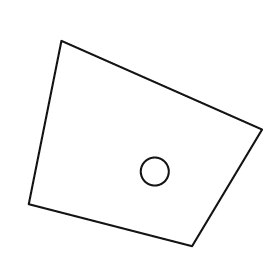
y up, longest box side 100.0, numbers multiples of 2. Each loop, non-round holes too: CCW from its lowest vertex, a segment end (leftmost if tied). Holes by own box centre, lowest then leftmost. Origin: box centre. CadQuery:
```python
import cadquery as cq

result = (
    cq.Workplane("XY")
    .moveTo(20.0, -44.0)
    .lineTo(50.0, 6.0)
    .lineTo(-36.0, 44.0)
    .lineTo(-50.0, -26.0)
    .close()
    .moveTo(4.0, -12.0)
    .circle(6.0)
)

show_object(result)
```